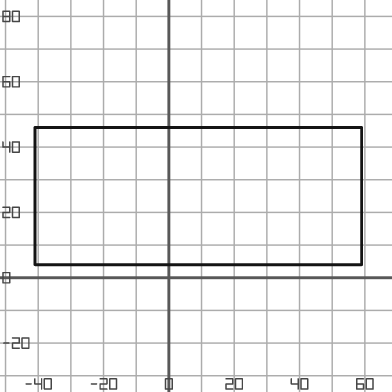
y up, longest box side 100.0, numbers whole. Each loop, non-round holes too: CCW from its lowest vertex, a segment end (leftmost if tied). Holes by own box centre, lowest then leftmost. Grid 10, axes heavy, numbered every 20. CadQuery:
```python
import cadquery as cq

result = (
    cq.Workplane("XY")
    .moveTo(-41.0, 4.0)
    .lineTo(59.0, 4.0)
    .lineTo(59.0, 46.0)
    .lineTo(-41.0, 46.0)
    .close()
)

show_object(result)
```